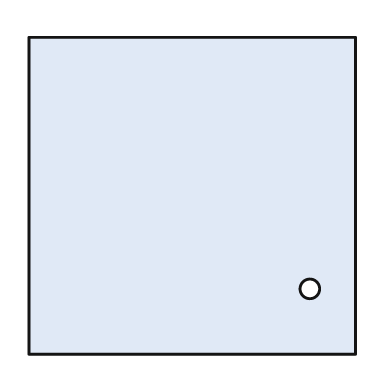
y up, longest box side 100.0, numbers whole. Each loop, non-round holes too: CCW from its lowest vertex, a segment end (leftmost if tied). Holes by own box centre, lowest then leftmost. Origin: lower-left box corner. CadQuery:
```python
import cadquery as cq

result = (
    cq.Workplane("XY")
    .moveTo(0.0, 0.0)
    .lineTo(100.0, 0.0)
    .lineTo(100.0, 97.0)
    .lineTo(0.0, 97.0)
    .close()
    .moveTo(86.0, 20.0)
    .circle(3.0)
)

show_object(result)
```